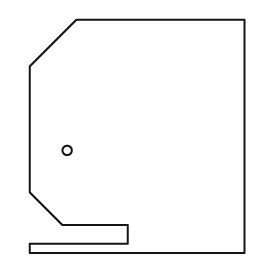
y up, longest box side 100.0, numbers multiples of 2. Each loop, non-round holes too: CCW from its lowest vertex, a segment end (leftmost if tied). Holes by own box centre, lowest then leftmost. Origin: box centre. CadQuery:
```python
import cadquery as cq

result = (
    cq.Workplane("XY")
    .moveTo(-46.0, -50.0)
    .lineTo(46.0, -50.0)
    .lineTo(46.0, 50.0)
    .lineTo(-26.0, 50.0)
    .lineTo(-46.0, 30.0)
    .lineTo(-46.0, -24.0)
    .lineTo(-32.0, -38.0)
    .lineTo(-4.0, -38.0)
    .lineTo(-4.0, -46.0)
    .lineTo(-46.0, -46.0)
    .close()
    .moveTo(-30.0, -6.0)
    .circle(2.0)
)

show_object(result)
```